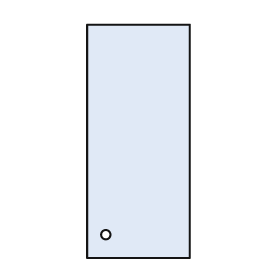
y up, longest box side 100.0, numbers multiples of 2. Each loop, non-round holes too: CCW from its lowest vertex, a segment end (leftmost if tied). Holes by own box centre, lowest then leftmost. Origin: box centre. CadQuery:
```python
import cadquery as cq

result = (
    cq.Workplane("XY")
    .moveTo(-22.0, -50.0)
    .lineTo(22.0, -50.0)
    .lineTo(22.0, 50.0)
    .lineTo(-22.0, 50.0)
    .close()
    .moveTo(-14.0, -40.0)
    .circle(2.0)
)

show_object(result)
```